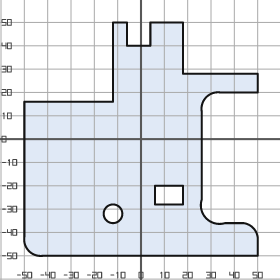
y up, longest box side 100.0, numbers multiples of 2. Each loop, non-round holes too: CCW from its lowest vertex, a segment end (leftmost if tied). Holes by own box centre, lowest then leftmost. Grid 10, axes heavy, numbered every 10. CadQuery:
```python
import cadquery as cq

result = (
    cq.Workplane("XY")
    .moveTo(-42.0, -50.0)
    .lineTo(50.0, -50.0)
    .lineTo(50.0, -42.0)
    .threePointArc((48.0, -38.0), (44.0, -36.0))
    .lineTo(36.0, -36.0)
    .threePointArc((28.0, -34.0), (26.0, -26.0))
    .lineTo(26.0, 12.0)
    .threePointArc((28.0, 18.0), (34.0, 20.0))
    .lineTo(50.0, 20.0)
    .lineTo(50.0, 28.0)
    .lineTo(18.0, 28.0)
    .lineTo(18.0, 50.0)
    .lineTo(4.0, 50.0)
    .lineTo(4.0, 40.0)
    .lineTo(-6.0, 40.0)
    .lineTo(-6.0, 50.0)
    .lineTo(-12.0, 50.0)
    .lineTo(-12.0, 16.0)
    .lineTo(-50.0, 16.0)
    .lineTo(-50.0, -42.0)
    .threePointArc((-48.0, -48.0), (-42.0, -50.0))
    .close()
    .moveTo(-12.0, -32.0)
    .circle(4.0)
    .moveTo(6.0, -28.0)
    .lineTo(18.0, -28.0)
    .lineTo(18.0, -20.0)
    .lineTo(6.0, -20.0)
    .close()
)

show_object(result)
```